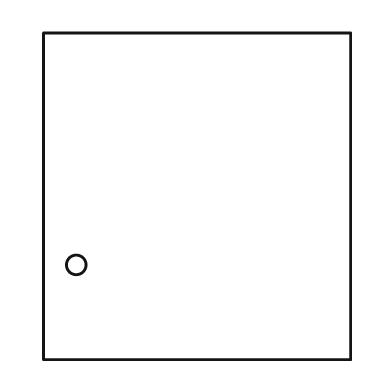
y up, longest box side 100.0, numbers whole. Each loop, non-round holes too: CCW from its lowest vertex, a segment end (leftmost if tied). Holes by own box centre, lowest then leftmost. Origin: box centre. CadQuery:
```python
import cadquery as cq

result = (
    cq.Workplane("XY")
    .moveTo(-47.0, -50.0)
    .lineTo(47.0, -50.0)
    .lineTo(47.0, 50.0)
    .lineTo(-47.0, 50.0)
    .close()
    .moveTo(-37.0, -21.0)
    .circle(3.0)
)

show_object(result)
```